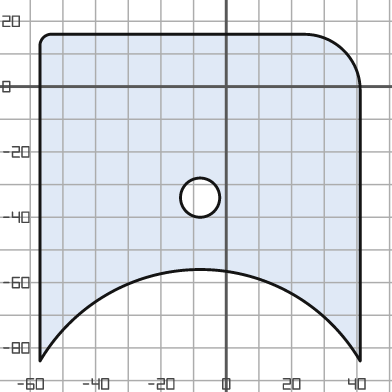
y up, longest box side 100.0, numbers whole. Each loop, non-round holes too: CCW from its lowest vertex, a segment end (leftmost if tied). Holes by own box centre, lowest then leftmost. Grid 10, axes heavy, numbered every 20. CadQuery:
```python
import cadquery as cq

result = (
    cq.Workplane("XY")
    .moveTo(-57.0, -84.0)
    .threePointArc((-8.0, -56.0), (41.0, -84.0))
    .lineTo(41.0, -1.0)
    .threePointArc((36.0, 11.0), (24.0, 16.0))
    .lineTo(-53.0, 16.0)
    .threePointArc((-56.0, 15.0), (-57.0, 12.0))
    .close()
    .moveTo(-8.0, -34.0)
    .circle(6.0)
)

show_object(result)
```